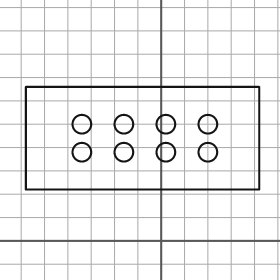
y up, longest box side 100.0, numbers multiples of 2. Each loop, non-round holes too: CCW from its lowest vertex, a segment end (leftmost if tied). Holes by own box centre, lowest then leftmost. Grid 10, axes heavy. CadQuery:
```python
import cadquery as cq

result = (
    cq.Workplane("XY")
    .moveTo(-58.0, 22.0)
    .lineTo(42.0, 22.0)
    .lineTo(42.0, 66.0)
    .lineTo(-58.0, 66.0)
    .close()
    .moveTo(-34.0, 38.0)
    .circle(4.0)
    .moveTo(-16.0, 38.0)
    .circle(4.0)
    .moveTo(2.0, 38.0)
    .circle(4.0)
    .moveTo(20.0, 38.0)
    .circle(4.0)
    .moveTo(-34.0, 50.0)
    .circle(4.0)
    .moveTo(-16.0, 50.0)
    .circle(4.0)
    .moveTo(2.0, 50.0)
    .circle(4.0)
    .moveTo(20.0, 50.0)
    .circle(4.0)
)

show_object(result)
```